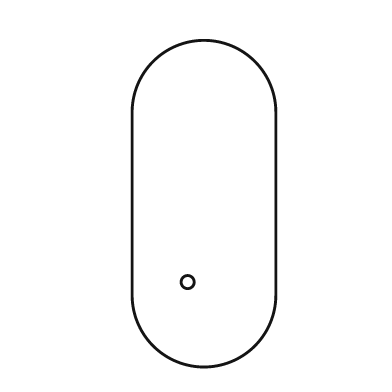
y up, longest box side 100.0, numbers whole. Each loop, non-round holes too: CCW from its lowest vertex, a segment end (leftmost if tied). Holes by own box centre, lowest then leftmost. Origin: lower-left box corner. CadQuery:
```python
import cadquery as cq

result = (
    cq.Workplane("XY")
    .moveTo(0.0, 22.0)
    .threePointArc((22.0, 0.0), (44.0, 22.0))
    .lineTo(44.0, 78.0)
    .threePointArc((22.0, 100.0), (0.0, 78.0))
    .close()
    .moveTo(17.0, 26.0)
    .circle(2.0)
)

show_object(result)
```